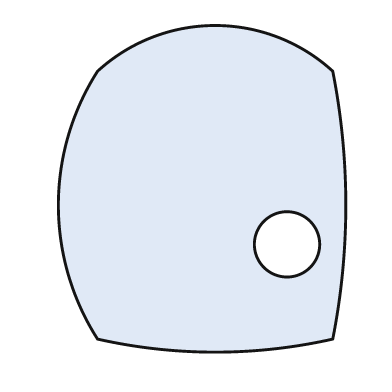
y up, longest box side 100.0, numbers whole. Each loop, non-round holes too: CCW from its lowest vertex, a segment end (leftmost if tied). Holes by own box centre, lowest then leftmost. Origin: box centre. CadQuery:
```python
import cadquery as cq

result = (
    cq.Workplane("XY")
    .moveTo(-32.0, -46.0)
    .threePointArc((4.0, -50.0), (40.0, -46.0))
    .threePointArc((44.0, -5.0), (40.0, 36.0))
    .threePointArc((4.0, 50.0), (-32.0, 36.0))
    .threePointArc((-44.0, -5.0), (-32.0, -46.0))
    .close()
    .moveTo(26.0, -17.0)
    .circle(10.0)
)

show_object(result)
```